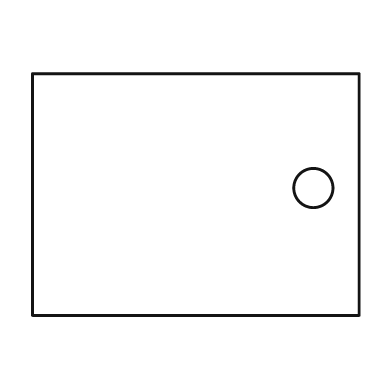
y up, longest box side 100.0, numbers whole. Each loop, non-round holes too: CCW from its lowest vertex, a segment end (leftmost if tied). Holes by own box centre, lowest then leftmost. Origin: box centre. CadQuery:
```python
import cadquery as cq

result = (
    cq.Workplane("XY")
    .moveTo(-50.0, -37.0)
    .lineTo(50.0, -37.0)
    .lineTo(50.0, 37.0)
    .lineTo(-50.0, 37.0)
    .close()
    .moveTo(36.0, 2.0)
    .circle(6.0)
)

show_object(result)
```